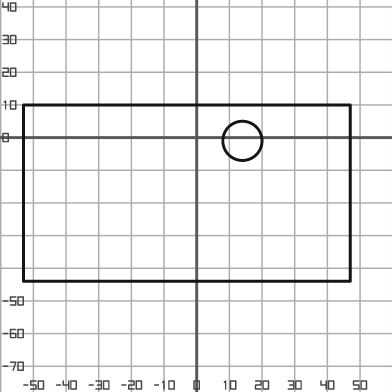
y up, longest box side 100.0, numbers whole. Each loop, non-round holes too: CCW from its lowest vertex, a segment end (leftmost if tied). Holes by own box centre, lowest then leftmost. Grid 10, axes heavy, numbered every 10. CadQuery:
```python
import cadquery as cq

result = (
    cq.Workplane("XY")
    .moveTo(-53.0, -44.0)
    .lineTo(47.0, -44.0)
    .lineTo(47.0, 10.0)
    .lineTo(-53.0, 10.0)
    .close()
    .moveTo(14.0, -1.0)
    .circle(6.0)
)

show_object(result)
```